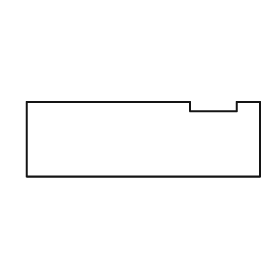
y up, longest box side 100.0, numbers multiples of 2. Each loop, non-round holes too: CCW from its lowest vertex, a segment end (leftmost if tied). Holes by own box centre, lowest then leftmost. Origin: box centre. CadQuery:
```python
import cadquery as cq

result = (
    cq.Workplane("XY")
    .moveTo(-50.0, -16.0)
    .lineTo(50.0, -16.0)
    .lineTo(50.0, 16.0)
    .lineTo(40.0, 16.0)
    .lineTo(40.0, 12.0)
    .lineTo(20.0, 12.0)
    .lineTo(20.0, 16.0)
    .lineTo(-50.0, 16.0)
    .close()
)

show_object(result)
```